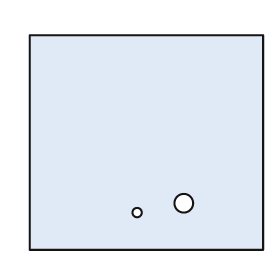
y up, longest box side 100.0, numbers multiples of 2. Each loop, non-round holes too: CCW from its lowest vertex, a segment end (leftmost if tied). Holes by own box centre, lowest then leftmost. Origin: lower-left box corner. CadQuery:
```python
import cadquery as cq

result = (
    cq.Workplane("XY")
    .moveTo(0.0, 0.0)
    .lineTo(100.0, 0.0)
    .lineTo(100.0, 92.0)
    .lineTo(0.0, 92.0)
    .close()
    .moveTo(46.0, 16.0)
    .circle(2.0)
    .moveTo(66.0, 20.0)
    .circle(4.0)
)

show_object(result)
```